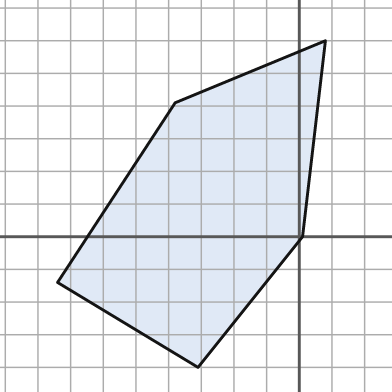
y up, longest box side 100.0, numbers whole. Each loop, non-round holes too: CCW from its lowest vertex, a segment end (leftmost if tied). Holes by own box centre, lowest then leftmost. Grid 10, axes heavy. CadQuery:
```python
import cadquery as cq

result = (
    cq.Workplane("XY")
    .moveTo(-31.0, -40.0)
    .lineTo(1.0, 0.0)
    .lineTo(8.0, 60.0)
    .lineTo(-38.0, 41.0)
    .lineTo(-74.0, -14.0)
    .close()
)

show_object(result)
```